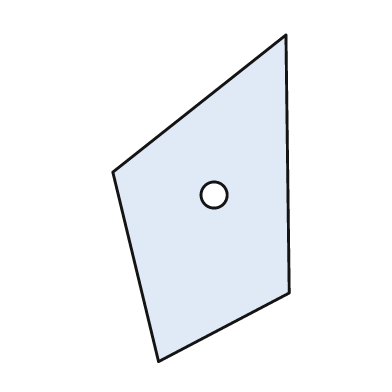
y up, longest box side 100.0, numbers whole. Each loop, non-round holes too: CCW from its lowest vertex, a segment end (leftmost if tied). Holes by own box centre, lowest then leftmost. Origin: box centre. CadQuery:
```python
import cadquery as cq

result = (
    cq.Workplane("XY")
    .moveTo(-13.0, -50.0)
    .lineTo(27.0, -29.0)
    .lineTo(26.0, 50.0)
    .lineTo(-27.0, 8.0)
    .close()
    .moveTo(4.0, 1.0)
    .circle(4.0)
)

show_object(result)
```